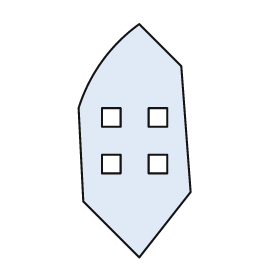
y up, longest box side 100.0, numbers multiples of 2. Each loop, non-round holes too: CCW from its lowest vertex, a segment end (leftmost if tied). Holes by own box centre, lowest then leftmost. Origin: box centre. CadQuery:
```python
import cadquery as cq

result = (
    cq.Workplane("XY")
    .moveTo(2.0, -50.0)
    .lineTo(24.0, -22.0)
    .lineTo(20.0, 32.0)
    .lineTo(2.0, 50.0)
    .threePointArc((-14.0, 34.0), (-24.0, 14.0))
    .lineTo(-22.0, -26.0)
    .close()
    .moveTo(-14.0, -14.0)
    .lineTo(-6.0, -14.0)
    .lineTo(-6.0, -6.0)
    .lineTo(-14.0, -6.0)
    .close()
    .moveTo(6.0, -14.0)
    .lineTo(14.0, -14.0)
    .lineTo(14.0, -6.0)
    .lineTo(6.0, -6.0)
    .close()
    .moveTo(-14.0, 6.0)
    .lineTo(-6.0, 6.0)
    .lineTo(-6.0, 14.0)
    .lineTo(-14.0, 14.0)
    .close()
    .moveTo(6.0, 6.0)
    .lineTo(14.0, 6.0)
    .lineTo(14.0, 14.0)
    .lineTo(6.0, 14.0)
    .close()
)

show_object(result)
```